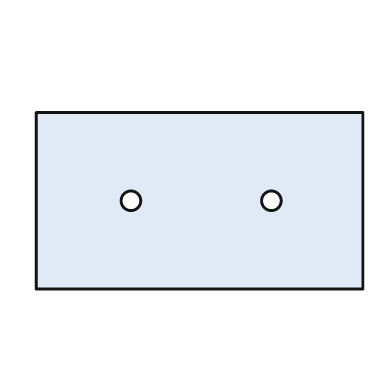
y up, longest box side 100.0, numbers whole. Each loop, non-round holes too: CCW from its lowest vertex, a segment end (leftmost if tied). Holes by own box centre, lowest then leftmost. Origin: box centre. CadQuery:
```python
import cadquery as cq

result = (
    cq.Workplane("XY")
    .moveTo(-50.0, -27.0)
    .lineTo(50.0, -27.0)
    .lineTo(50.0, 27.0)
    .lineTo(-50.0, 27.0)
    .close()
    .moveTo(-21.0, 0.0)
    .circle(3.0)
    .moveTo(22.0, 0.0)
    .circle(3.0)
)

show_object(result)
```